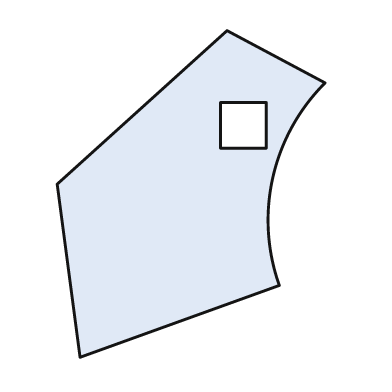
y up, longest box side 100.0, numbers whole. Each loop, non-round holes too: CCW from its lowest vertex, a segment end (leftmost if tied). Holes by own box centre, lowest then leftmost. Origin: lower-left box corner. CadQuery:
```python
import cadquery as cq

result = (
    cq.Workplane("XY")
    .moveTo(7.0, 0.0)
    .lineTo(68.0, 22.0)
    .threePointArc((66.0, 55.0), (82.0, 84.0))
    .lineTo(52.0, 100.0)
    .lineTo(0.0, 53.0)
    .close()
    .moveTo(50.0, 64.0)
    .lineTo(64.0, 64.0)
    .lineTo(64.0, 78.0)
    .lineTo(50.0, 78.0)
    .close()
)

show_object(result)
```